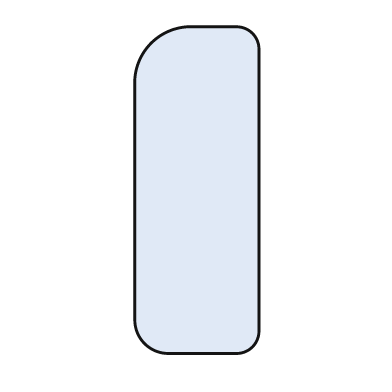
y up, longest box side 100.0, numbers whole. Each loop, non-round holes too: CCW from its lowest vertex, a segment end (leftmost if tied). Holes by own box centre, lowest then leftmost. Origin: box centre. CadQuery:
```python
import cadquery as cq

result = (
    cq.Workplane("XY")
    .moveTo(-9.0, -50.0)
    .lineTo(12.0, -50.0)
    .threePointArc((17.0, -48.0), (19.0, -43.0))
    .lineTo(19.0, 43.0)
    .threePointArc((17.0, 48.0), (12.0, 50.0))
    .lineTo(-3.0, 50.0)
    .threePointArc((-14.0, 45.0), (-19.0, 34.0))
    .lineTo(-19.0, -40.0)
    .threePointArc((-16.0, -47.0), (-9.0, -50.0))
    .close()
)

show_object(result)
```